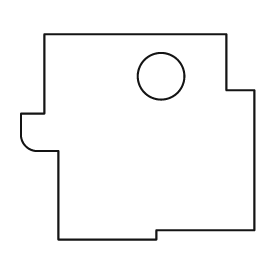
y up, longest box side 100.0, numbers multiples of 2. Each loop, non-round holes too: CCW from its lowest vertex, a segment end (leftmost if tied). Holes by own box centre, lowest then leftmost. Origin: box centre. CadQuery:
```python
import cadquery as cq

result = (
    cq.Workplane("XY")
    .moveTo(-34.0, -44.0)
    .lineTo(8.0, -44.0)
    .lineTo(8.0, -40.0)
    .lineTo(50.0, -40.0)
    .lineTo(50.0, 20.0)
    .lineTo(38.0, 20.0)
    .lineTo(38.0, 44.0)
    .lineTo(-40.0, 44.0)
    .lineTo(-40.0, 10.0)
    .lineTo(-50.0, 10.0)
    .lineTo(-50.0, 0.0)
    .threePointArc((-48.0, -4.0), (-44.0, -6.0))
    .lineTo(-34.0, -6.0)
    .close()
    .moveTo(10.0, 26.0)
    .circle(10.0)
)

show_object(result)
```